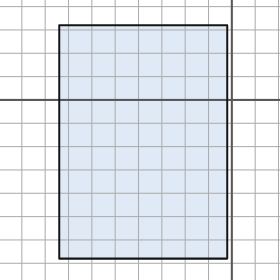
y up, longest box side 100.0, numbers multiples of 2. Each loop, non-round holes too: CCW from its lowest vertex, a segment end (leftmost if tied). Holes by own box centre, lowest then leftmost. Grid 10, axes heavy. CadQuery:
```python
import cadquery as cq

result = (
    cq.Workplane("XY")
    .moveTo(-74.0, -68.0)
    .lineTo(-2.0, -68.0)
    .lineTo(-2.0, 32.0)
    .lineTo(-74.0, 32.0)
    .close()
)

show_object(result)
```